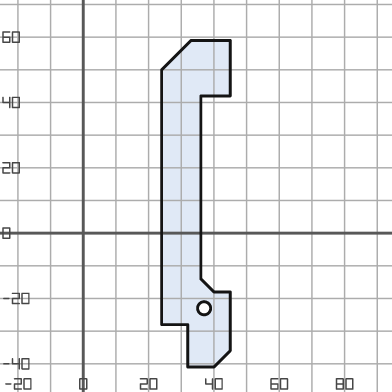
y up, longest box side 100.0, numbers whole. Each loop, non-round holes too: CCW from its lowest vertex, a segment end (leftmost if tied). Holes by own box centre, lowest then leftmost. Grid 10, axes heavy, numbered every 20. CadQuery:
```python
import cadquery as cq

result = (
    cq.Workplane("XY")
    .moveTo(32.0, -41.0)
    .lineTo(40.0, -41.0)
    .lineTo(45.0, -36.0)
    .lineTo(45.0, -18.0)
    .lineTo(40.0, -18.0)
    .lineTo(36.0, -14.0)
    .lineTo(36.0, 42.0)
    .lineTo(45.0, 42.0)
    .lineTo(45.0, 59.0)
    .lineTo(33.0, 59.0)
    .lineTo(24.0, 50.0)
    .lineTo(24.0, -28.0)
    .lineTo(32.0, -28.0)
    .close()
    .moveTo(37.0, -23.0)
    .circle(2.0)
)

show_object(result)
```